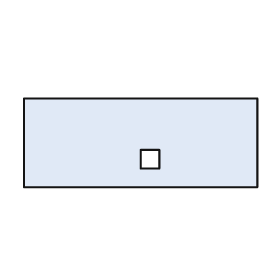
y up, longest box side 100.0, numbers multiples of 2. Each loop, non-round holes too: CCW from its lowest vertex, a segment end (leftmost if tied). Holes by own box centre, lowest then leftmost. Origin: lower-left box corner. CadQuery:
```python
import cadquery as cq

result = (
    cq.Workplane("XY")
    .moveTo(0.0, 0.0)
    .lineTo(100.0, 0.0)
    .lineTo(100.0, 38.0)
    .lineTo(0.0, 38.0)
    .close()
    .moveTo(50.0, 8.0)
    .lineTo(58.0, 8.0)
    .lineTo(58.0, 16.0)
    .lineTo(50.0, 16.0)
    .close()
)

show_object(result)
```